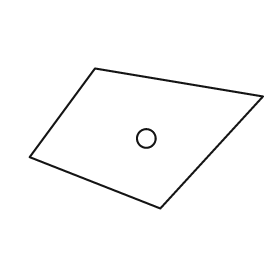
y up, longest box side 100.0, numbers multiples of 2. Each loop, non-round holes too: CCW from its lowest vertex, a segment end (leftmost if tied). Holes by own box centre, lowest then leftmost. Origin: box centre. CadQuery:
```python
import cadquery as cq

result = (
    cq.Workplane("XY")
    .moveTo(6.0, -30.0)
    .lineTo(50.0, 18.0)
    .lineTo(-22.0, 30.0)
    .lineTo(-50.0, -8.0)
    .close()
    .moveTo(0.0, 0.0)
    .circle(4.0)
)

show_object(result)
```